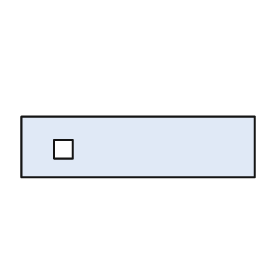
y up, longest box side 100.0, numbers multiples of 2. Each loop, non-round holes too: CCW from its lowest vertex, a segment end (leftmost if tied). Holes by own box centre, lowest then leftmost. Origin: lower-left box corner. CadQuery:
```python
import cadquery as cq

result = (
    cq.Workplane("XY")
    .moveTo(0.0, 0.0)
    .lineTo(100.0, 0.0)
    .lineTo(100.0, 26.0)
    .lineTo(0.0, 26.0)
    .close()
    .moveTo(14.0, 8.0)
    .lineTo(22.0, 8.0)
    .lineTo(22.0, 16.0)
    .lineTo(14.0, 16.0)
    .close()
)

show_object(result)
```